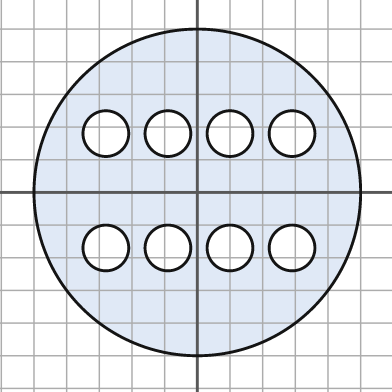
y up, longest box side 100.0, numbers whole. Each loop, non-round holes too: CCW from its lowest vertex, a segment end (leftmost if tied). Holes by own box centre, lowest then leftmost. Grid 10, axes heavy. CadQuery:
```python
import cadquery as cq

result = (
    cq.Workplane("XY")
    .moveTo(0.0, 0.0)
    .circle(50.0)
    .moveTo(-28.0, -17.0)
    .circle(7.0)
    .moveTo(-9.0, -17.0)
    .circle(7.0)
    .moveTo(10.0, -17.0)
    .circle(7.0)
    .moveTo(29.0, -17.0)
    .circle(7.0)
    .moveTo(-28.0, 18.0)
    .circle(7.0)
    .moveTo(-9.0, 18.0)
    .circle(7.0)
    .moveTo(10.0, 18.0)
    .circle(7.0)
    .moveTo(29.0, 18.0)
    .circle(7.0)
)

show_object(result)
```